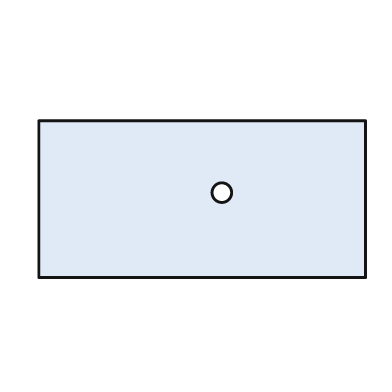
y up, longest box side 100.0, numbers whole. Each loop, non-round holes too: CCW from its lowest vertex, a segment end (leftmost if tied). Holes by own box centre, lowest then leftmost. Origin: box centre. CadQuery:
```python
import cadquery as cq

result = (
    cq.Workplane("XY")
    .moveTo(-50.0, -24.0)
    .lineTo(50.0, -24.0)
    .lineTo(50.0, 24.0)
    .lineTo(-50.0, 24.0)
    .close()
    .moveTo(6.0, 2.0)
    .circle(3.0)
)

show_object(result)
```